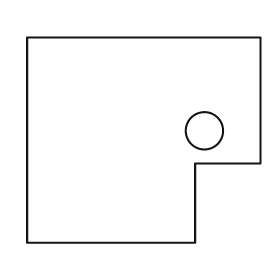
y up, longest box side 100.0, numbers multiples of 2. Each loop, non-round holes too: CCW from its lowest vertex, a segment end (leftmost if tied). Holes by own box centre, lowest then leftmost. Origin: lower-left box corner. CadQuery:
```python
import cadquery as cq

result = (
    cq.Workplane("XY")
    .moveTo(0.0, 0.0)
    .lineTo(72.0, 0.0)
    .lineTo(72.0, 34.0)
    .lineTo(100.0, 34.0)
    .lineTo(100.0, 88.0)
    .lineTo(0.0, 88.0)
    .close()
    .moveTo(76.0, 48.0)
    .circle(8.0)
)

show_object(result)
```